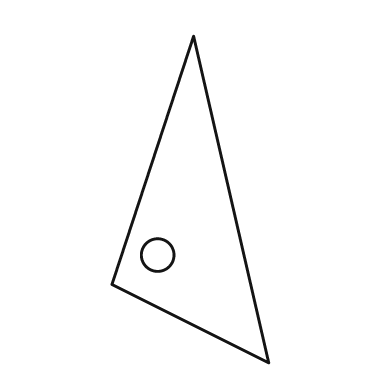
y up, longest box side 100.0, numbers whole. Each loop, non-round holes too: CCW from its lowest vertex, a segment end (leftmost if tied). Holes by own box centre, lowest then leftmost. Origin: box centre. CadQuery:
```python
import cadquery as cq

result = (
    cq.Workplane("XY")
    .moveTo(24.0, -50.0)
    .lineTo(1.0, 50.0)
    .lineTo(-24.0, -26.0)
    .close()
    .moveTo(-10.0, -17.0)
    .circle(5.0)
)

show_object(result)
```